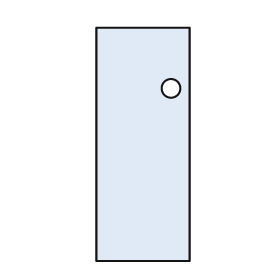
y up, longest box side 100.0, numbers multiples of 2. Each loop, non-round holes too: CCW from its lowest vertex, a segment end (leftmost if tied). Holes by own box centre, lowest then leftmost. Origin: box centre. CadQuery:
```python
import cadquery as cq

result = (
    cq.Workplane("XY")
    .moveTo(-20.0, -50.0)
    .lineTo(20.0, -50.0)
    .lineTo(20.0, 50.0)
    .lineTo(-20.0, 50.0)
    .close()
    .moveTo(12.0, 24.0)
    .circle(4.0)
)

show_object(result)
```